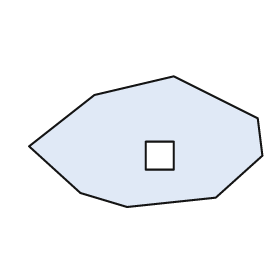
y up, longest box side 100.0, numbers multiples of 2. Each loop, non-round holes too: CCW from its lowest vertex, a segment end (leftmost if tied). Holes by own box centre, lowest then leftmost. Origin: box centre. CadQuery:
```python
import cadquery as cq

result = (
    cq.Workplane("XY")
    .moveTo(-8.0, -28.0)
    .lineTo(30.0, -24.0)
    .lineTo(50.0, -6.0)
    .lineTo(48.0, 10.0)
    .lineTo(12.0, 28.0)
    .lineTo(-22.0, 20.0)
    .lineTo(-50.0, -2.0)
    .lineTo(-28.0, -22.0)
    .close()
    .moveTo(0.0, -12.0)
    .lineTo(12.0, -12.0)
    .lineTo(12.0, 0.0)
    .lineTo(0.0, 0.0)
    .close()
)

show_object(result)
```